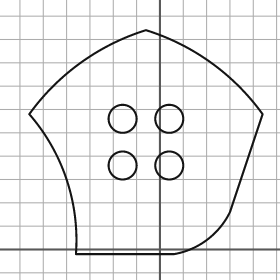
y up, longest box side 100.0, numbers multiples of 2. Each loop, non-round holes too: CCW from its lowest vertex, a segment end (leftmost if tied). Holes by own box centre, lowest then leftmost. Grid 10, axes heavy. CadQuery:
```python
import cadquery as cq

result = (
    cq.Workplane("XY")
    .moveTo(-36.0, -2.0)
    .lineTo(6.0, -2.0)
    .threePointArc((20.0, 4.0), (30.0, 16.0))
    .lineTo(44.0, 58.0)
    .threePointArc((22.0, 80.0), (-6.0, 94.0))
    .threePointArc((-34.0, 80.0), (-56.0, 58.0))
    .threePointArc((-40.0, 30.0), (-36.0, -2.0))
    .close()
    .moveTo(-16.0, 36.0)
    .circle(6.0)
    .moveTo(4.0, 36.0)
    .circle(6.0)
    .moveTo(-16.0, 56.0)
    .circle(6.0)
    .moveTo(4.0, 56.0)
    .circle(6.0)
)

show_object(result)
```